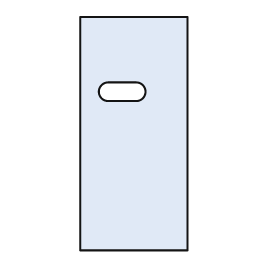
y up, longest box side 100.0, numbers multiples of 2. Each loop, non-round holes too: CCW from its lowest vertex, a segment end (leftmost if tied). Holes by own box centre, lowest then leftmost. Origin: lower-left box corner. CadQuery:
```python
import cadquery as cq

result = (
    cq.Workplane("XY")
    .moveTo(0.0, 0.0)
    .lineTo(46.0, 0.0)
    .lineTo(46.0, 100.0)
    .lineTo(0.0, 100.0)
    .close()
    .moveTo(12.0, 64.0)
    .lineTo(24.0, 64.0)
    .threePointArc((28.0, 68.0), (24.0, 72.0))
    .lineTo(12.0, 72.0)
    .threePointArc((8.0, 68.0), (12.0, 64.0))
    .close()
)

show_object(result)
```